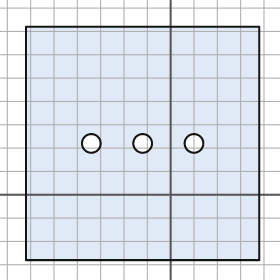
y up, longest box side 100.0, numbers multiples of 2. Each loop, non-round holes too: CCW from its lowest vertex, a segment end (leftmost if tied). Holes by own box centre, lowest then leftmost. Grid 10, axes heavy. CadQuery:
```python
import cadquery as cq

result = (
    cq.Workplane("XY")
    .moveTo(-62.0, -28.0)
    .lineTo(38.0, -28.0)
    .lineTo(38.0, 72.0)
    .lineTo(-62.0, 72.0)
    .close()
    .moveTo(-34.0, 22.0)
    .circle(4.0)
    .moveTo(-12.0, 22.0)
    .circle(4.0)
    .moveTo(10.0, 22.0)
    .circle(4.0)
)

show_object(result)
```